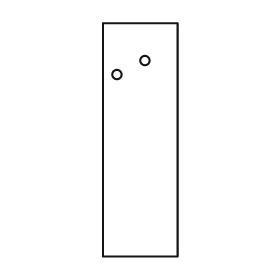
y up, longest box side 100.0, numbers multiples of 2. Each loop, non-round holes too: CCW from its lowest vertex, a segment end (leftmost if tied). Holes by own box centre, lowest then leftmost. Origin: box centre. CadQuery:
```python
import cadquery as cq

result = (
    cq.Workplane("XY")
    .moveTo(-16.0, -50.0)
    .lineTo(16.0, -50.0)
    .lineTo(16.0, 50.0)
    .lineTo(-16.0, 50.0)
    .close()
    .moveTo(-10.0, 28.0)
    .circle(2.0)
    .moveTo(2.0, 34.0)
    .circle(2.0)
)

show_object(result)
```